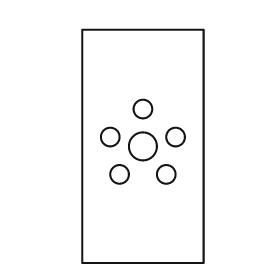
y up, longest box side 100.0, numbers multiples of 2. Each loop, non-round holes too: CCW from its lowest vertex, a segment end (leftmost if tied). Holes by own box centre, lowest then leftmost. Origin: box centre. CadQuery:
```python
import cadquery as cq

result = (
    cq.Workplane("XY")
    .moveTo(-26.0, -50.0)
    .lineTo(26.0, -50.0)
    .lineTo(26.0, 50.0)
    .lineTo(-26.0, 50.0)
    .close()
    .moveTo(-10.0, -12.0)
    .circle(4.0)
    .moveTo(10.0, -12.0)
    .circle(4.0)
    .moveTo(0.0, 0.0)
    .circle(6.0)
    .moveTo(-14.0, 4.0)
    .circle(4.0)
    .moveTo(14.0, 4.0)
    .circle(4.0)
    .moveTo(0.0, 16.0)
    .circle(4.0)
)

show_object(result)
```